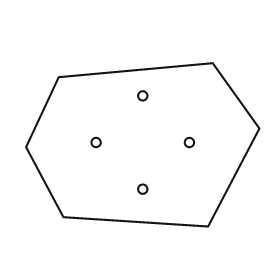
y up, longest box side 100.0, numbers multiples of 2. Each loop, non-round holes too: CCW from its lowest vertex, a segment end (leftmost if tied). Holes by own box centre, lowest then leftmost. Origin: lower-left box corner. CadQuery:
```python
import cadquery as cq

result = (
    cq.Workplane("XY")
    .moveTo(78.0, 0.0)
    .lineTo(100.0, 42.0)
    .lineTo(80.0, 70.0)
    .lineTo(14.0, 64.0)
    .lineTo(0.0, 34.0)
    .lineTo(16.0, 4.0)
    .close()
    .moveTo(50.0, 16.0)
    .circle(2.0)
    .moveTo(30.0, 36.0)
    .circle(2.0)
    .moveTo(70.0, 36.0)
    .circle(2.0)
    .moveTo(50.0, 56.0)
    .circle(2.0)
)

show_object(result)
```